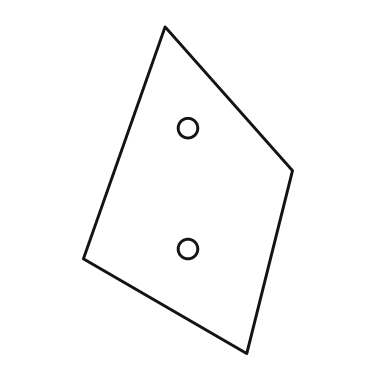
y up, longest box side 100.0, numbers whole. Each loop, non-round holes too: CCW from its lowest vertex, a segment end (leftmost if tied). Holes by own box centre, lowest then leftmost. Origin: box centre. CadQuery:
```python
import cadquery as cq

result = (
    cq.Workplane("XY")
    .moveTo(18.0, -50.0)
    .lineTo(32.0, 6.0)
    .lineTo(-7.0, 50.0)
    .lineTo(-32.0, -21.0)
    .close()
    .moveTo(0.0, -18.0)
    .circle(3.0)
    .moveTo(0.0, 19.0)
    .circle(3.0)
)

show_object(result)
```